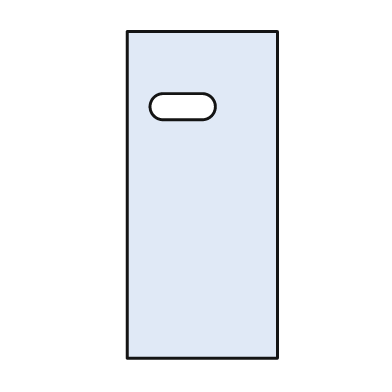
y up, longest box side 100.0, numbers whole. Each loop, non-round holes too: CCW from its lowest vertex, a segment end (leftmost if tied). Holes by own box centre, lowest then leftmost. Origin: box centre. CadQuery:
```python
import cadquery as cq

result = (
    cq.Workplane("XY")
    .moveTo(-23.0, -50.0)
    .lineTo(23.0, -50.0)
    .lineTo(23.0, 50.0)
    .lineTo(-23.0, 50.0)
    .close()
    .moveTo(-12.0, 23.0)
    .lineTo(0.0, 23.0)
    .threePointArc((4.0, 27.0), (0.0, 31.0))
    .lineTo(-12.0, 31.0)
    .threePointArc((-16.0, 27.0), (-12.0, 23.0))
    .close()
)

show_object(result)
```